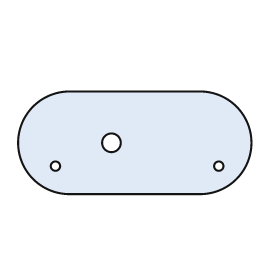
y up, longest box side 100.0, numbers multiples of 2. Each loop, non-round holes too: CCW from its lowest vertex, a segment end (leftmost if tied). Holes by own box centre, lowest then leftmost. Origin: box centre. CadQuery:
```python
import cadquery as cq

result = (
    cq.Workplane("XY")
    .moveTo(-28.0, -22.0)
    .lineTo(28.0, -22.0)
    .threePointArc((50.0, 0.0), (28.0, 22.0))
    .lineTo(-28.0, 22.0)
    .threePointArc((-50.0, 0.0), (-28.0, -22.0))
    .close()
    .moveTo(-34.0, -10.0)
    .circle(2.0)
    .moveTo(36.0, -10.0)
    .circle(2.0)
    .moveTo(-10.0, 0.0)
    .circle(4.0)
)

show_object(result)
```